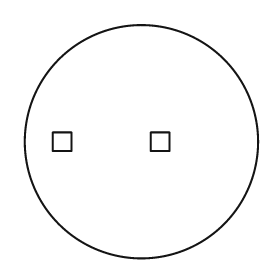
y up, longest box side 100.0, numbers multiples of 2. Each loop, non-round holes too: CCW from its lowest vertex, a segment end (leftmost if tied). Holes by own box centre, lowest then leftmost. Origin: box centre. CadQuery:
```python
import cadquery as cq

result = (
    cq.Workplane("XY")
    .moveTo(0.0, 0.0)
    .circle(50.0)
    .moveTo(-38.0, -4.0)
    .lineTo(-30.0, -4.0)
    .lineTo(-30.0, 4.0)
    .lineTo(-38.0, 4.0)
    .close()
    .moveTo(4.0, -4.0)
    .lineTo(12.0, -4.0)
    .lineTo(12.0, 4.0)
    .lineTo(4.0, 4.0)
    .close()
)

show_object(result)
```